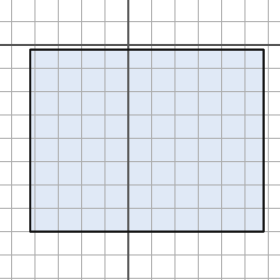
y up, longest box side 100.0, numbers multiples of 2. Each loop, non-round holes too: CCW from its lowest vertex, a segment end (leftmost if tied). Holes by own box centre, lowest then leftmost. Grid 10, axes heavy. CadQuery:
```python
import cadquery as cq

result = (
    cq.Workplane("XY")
    .moveTo(-42.0, -80.0)
    .lineTo(58.0, -80.0)
    .lineTo(58.0, -2.0)
    .lineTo(-42.0, -2.0)
    .close()
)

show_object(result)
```